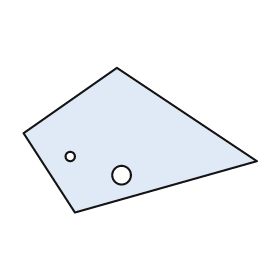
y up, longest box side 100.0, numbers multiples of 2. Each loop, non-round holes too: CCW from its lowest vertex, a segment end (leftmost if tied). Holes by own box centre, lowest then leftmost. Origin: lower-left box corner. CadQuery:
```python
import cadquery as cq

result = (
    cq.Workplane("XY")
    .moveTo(22.0, 0.0)
    .lineTo(100.0, 22.0)
    .lineTo(40.0, 62.0)
    .lineTo(0.0, 34.0)
    .close()
    .moveTo(42.0, 16.0)
    .circle(4.0)
    .moveTo(20.0, 24.0)
    .circle(2.0)
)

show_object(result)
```